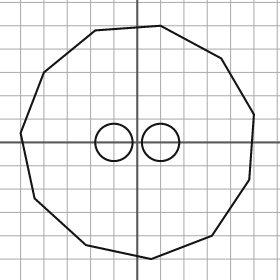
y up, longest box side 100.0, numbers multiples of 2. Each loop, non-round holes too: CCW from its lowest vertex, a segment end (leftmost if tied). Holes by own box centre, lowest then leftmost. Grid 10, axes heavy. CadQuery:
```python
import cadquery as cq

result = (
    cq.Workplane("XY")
    .moveTo(6.0, -50.0)
    .lineTo(32.0, -40.0)
    .lineTo(48.0, -16.0)
    .lineTo(50.0, 12.0)
    .lineTo(36.0, 36.0)
    .lineTo(10.0, 50.0)
    .lineTo(-18.0, 48.0)
    .lineTo(-40.0, 30.0)
    .lineTo(-50.0, 4.0)
    .lineTo(-44.0, -24.0)
    .lineTo(-22.0, -44.0)
    .close()
    .moveTo(-10.0, 0.0)
    .circle(8.0)
    .moveTo(10.0, 0.0)
    .circle(8.0)
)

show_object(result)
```